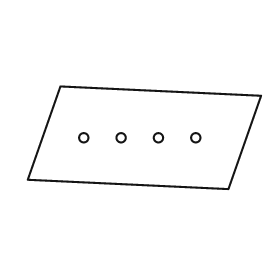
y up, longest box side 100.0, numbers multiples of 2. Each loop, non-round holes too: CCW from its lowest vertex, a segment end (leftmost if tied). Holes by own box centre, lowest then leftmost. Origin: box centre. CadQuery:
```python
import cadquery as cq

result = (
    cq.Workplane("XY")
    .moveTo(36.0, -22.0)
    .lineTo(50.0, 18.0)
    .lineTo(-36.0, 22.0)
    .lineTo(-50.0, -18.0)
    .close()
    .moveTo(-26.0, 0.0)
    .circle(2.0)
    .moveTo(-10.0, 0.0)
    .circle(2.0)
    .moveTo(6.0, 0.0)
    .circle(2.0)
    .moveTo(22.0, 0.0)
    .circle(2.0)
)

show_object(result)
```